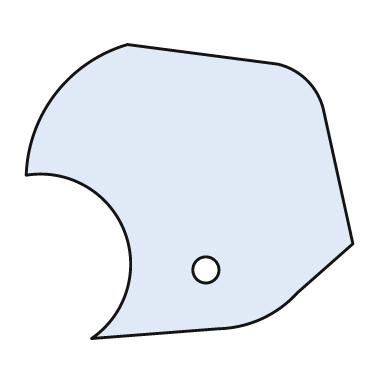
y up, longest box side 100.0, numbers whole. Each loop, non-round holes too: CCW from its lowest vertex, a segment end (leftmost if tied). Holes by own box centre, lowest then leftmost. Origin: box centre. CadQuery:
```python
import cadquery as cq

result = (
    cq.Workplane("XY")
    .moveTo(-30.0, -45.0)
    .lineTo(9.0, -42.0)
    .threePointArc((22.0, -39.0), (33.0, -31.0))
    .lineTo(50.0, -16.0)
    .lineTo(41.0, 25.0)
    .threePointArc((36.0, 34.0), (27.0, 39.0))
    .lineTo(-19.0, 45.0)
    .threePointArc((-41.0, 30.0), (-50.0, 5.0))
    .threePointArc((-20.0, -12.0), (-30.0, -45.0))
    .close()
    .moveTo(5.0, -24.0)
    .circle(4.0)
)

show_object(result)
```